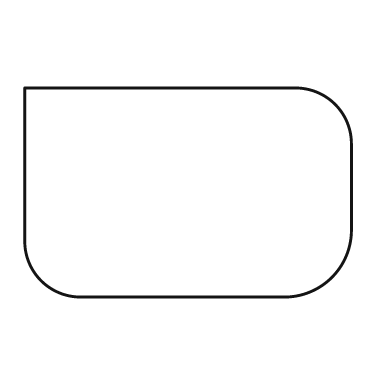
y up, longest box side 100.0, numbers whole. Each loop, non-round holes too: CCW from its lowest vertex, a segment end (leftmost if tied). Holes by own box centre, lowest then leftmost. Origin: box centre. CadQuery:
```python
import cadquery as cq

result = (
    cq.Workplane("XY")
    .moveTo(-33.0, -32.0)
    .lineTo(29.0, -32.0)
    .threePointArc((44.0, -26.0), (50.0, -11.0))
    .lineTo(50.0, 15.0)
    .threePointArc((45.0, 27.0), (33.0, 32.0))
    .lineTo(-50.0, 32.0)
    .lineTo(-50.0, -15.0)
    .threePointArc((-45.0, -27.0), (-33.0, -32.0))
    .close()
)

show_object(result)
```